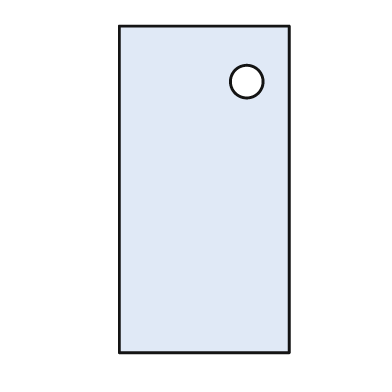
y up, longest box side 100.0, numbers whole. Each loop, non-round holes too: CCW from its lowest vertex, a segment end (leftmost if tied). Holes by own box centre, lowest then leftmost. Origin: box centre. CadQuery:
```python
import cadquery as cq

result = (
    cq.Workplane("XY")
    .moveTo(-26.0, -50.0)
    .lineTo(26.0, -50.0)
    .lineTo(26.0, 50.0)
    .lineTo(-26.0, 50.0)
    .close()
    .moveTo(13.0, 33.0)
    .circle(5.0)
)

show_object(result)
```